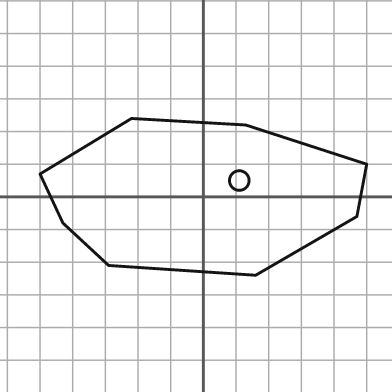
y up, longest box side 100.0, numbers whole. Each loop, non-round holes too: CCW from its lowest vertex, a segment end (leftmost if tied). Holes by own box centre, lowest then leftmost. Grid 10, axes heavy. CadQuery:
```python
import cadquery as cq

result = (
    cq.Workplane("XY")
    .moveTo(16.0, -24.0)
    .lineTo(47.0, -6.0)
    .lineTo(50.0, 10.0)
    .lineTo(13.0, 22.0)
    .lineTo(-22.0, 24.0)
    .lineTo(-50.0, 7.0)
    .lineTo(-43.0, -8.0)
    .lineTo(-29.0, -21.0)
    .close()
    .moveTo(11.0, 5.0)
    .circle(3.0)
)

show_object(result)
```